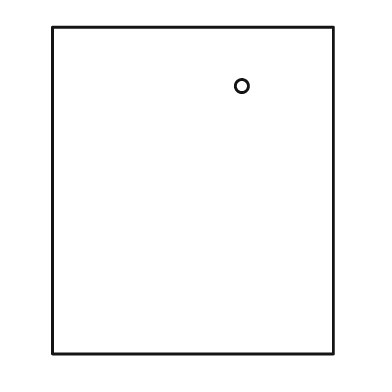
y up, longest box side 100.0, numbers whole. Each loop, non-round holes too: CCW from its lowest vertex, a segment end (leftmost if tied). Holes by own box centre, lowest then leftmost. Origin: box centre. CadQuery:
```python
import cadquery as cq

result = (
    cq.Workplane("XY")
    .moveTo(-43.0, -50.0)
    .lineTo(43.0, -50.0)
    .lineTo(43.0, 50.0)
    .lineTo(-43.0, 50.0)
    .close()
    .moveTo(15.0, 32.0)
    .circle(2.0)
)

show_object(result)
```